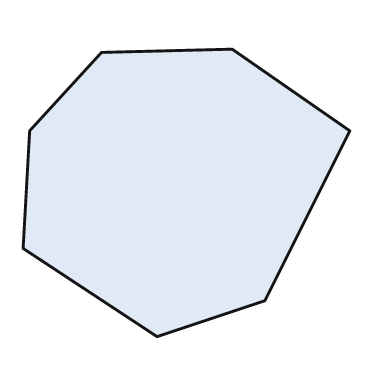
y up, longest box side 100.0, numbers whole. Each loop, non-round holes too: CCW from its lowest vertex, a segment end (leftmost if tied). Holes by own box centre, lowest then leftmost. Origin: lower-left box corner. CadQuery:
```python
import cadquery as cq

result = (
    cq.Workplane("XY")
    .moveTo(41.0, 0.0)
    .lineTo(74.0, 11.0)
    .lineTo(100.0, 63.0)
    .lineTo(64.0, 88.0)
    .lineTo(24.0, 87.0)
    .lineTo(2.0, 63.0)
    .lineTo(0.0, 27.0)
    .close()
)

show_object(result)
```